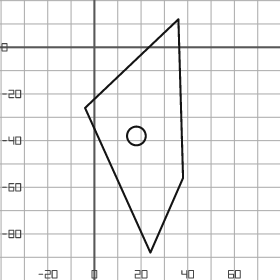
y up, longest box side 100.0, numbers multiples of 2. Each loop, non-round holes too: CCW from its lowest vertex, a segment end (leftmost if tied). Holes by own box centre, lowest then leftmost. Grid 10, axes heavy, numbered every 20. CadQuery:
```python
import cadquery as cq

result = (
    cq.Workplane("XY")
    .moveTo(24.0, -88.0)
    .lineTo(38.0, -56.0)
    .lineTo(36.0, 12.0)
    .lineTo(-4.0, -26.0)
    .close()
    .moveTo(18.0, -38.0)
    .circle(4.0)
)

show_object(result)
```